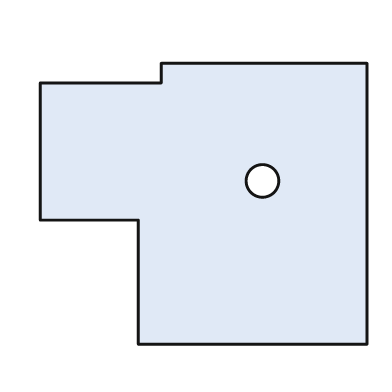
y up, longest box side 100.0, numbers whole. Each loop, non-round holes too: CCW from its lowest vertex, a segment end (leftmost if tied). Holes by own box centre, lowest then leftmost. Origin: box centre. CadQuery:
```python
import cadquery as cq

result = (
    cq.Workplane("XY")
    .moveTo(-20.0, -43.0)
    .lineTo(50.0, -43.0)
    .lineTo(50.0, 43.0)
    .lineTo(-13.0, 43.0)
    .lineTo(-13.0, 37.0)
    .lineTo(-50.0, 37.0)
    .lineTo(-50.0, -5.0)
    .lineTo(-20.0, -5.0)
    .close()
    .moveTo(18.0, 7.0)
    .circle(5.0)
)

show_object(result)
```